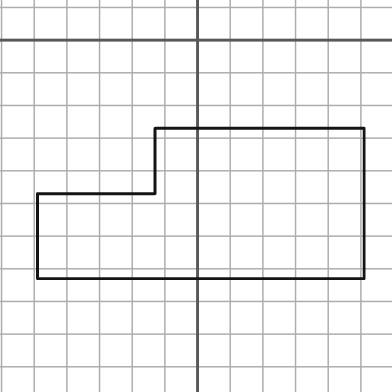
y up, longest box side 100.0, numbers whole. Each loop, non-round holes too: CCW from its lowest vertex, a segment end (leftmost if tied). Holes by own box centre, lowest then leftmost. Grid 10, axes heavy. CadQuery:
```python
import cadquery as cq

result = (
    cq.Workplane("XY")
    .moveTo(-49.0, -73.0)
    .lineTo(51.0, -73.0)
    .lineTo(51.0, -27.0)
    .lineTo(-13.0, -27.0)
    .lineTo(-13.0, -47.0)
    .lineTo(-49.0, -47.0)
    .close()
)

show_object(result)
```